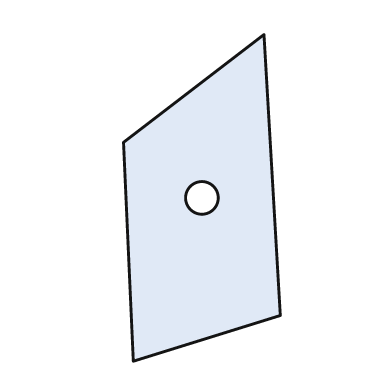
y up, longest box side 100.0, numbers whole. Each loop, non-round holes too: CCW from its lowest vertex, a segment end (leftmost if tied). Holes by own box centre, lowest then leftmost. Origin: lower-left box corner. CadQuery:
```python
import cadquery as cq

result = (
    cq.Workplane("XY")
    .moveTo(3.0, 0.0)
    .lineTo(48.0, 14.0)
    .lineTo(43.0, 100.0)
    .lineTo(0.0, 67.0)
    .close()
    .moveTo(24.0, 50.0)
    .circle(5.0)
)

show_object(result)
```